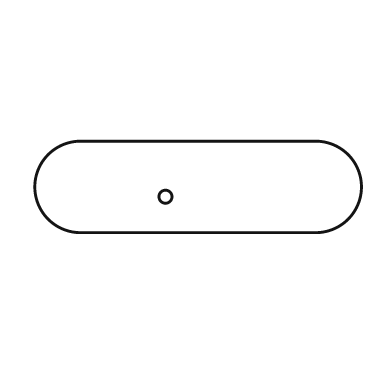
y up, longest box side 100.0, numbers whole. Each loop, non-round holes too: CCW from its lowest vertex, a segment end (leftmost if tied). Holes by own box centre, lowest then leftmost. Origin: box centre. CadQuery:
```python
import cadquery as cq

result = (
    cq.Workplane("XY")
    .moveTo(-36.0, -14.0)
    .lineTo(36.0, -14.0)
    .threePointArc((50.0, 0.0), (36.0, 14.0))
    .lineTo(-36.0, 14.0)
    .threePointArc((-50.0, 0.0), (-36.0, -14.0))
    .close()
    .moveTo(-10.0, -3.0)
    .circle(2.0)
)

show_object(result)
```